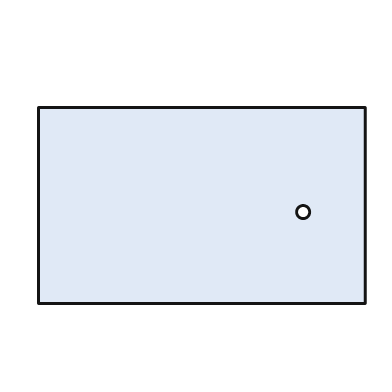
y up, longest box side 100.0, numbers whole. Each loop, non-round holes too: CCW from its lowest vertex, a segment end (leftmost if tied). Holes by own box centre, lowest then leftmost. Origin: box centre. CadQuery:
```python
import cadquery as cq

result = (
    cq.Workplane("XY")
    .moveTo(-50.0, -30.0)
    .lineTo(50.0, -30.0)
    .lineTo(50.0, 30.0)
    .lineTo(-50.0, 30.0)
    .close()
    .moveTo(31.0, -2.0)
    .circle(2.0)
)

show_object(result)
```